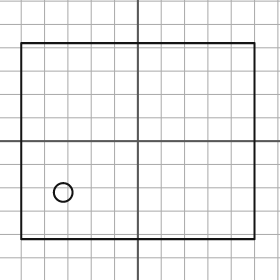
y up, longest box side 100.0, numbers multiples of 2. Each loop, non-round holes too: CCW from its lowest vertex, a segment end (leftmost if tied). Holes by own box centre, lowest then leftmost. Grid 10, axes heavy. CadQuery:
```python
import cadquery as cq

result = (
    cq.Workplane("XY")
    .moveTo(-50.0, -42.0)
    .lineTo(50.0, -42.0)
    .lineTo(50.0, 42.0)
    .lineTo(-50.0, 42.0)
    .close()
    .moveTo(-32.0, -22.0)
    .circle(4.0)
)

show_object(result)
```